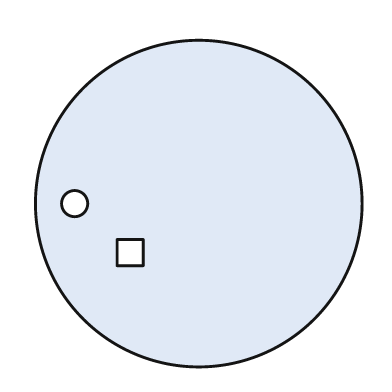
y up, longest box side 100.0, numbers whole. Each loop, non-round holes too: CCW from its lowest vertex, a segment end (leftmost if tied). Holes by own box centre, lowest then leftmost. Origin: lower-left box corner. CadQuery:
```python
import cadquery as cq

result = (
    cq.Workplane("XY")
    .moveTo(50.0, 50.0)
    .circle(50.0)
    .moveTo(25.0, 31.0)
    .lineTo(33.0, 31.0)
    .lineTo(33.0, 39.0)
    .lineTo(25.0, 39.0)
    .close()
    .moveTo(12.0, 50.0)
    .circle(4.0)
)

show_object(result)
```